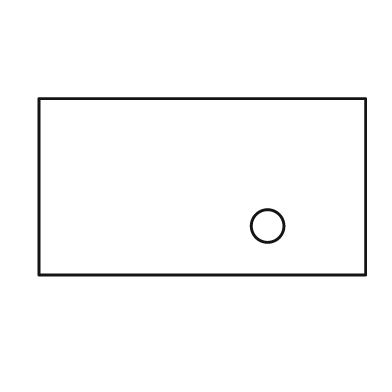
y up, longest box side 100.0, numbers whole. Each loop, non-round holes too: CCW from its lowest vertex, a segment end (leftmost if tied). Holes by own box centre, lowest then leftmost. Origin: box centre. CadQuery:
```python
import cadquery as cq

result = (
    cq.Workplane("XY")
    .moveTo(-50.0, -27.0)
    .lineTo(50.0, -27.0)
    .lineTo(50.0, 27.0)
    .lineTo(-50.0, 27.0)
    .close()
    .moveTo(20.0, -12.0)
    .circle(5.0)
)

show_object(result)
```